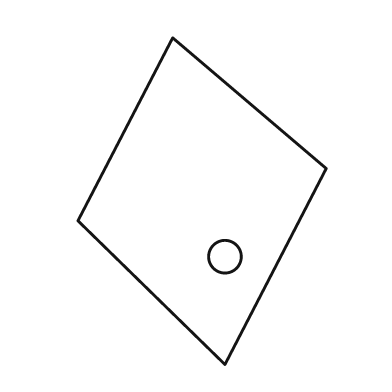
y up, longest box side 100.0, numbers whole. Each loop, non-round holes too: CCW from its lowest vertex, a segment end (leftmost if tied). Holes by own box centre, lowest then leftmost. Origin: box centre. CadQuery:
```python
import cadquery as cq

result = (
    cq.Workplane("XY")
    .moveTo(7.0, -50.0)
    .lineTo(38.0, 10.0)
    .lineTo(-9.0, 50.0)
    .lineTo(-38.0, -6.0)
    .close()
    .moveTo(7.0, -17.0)
    .circle(5.0)
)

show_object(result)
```